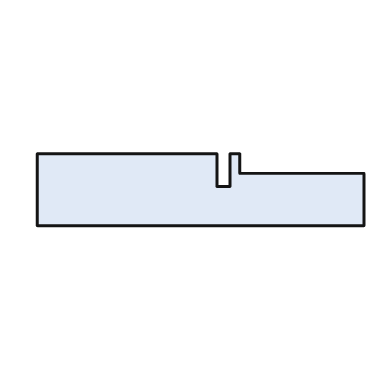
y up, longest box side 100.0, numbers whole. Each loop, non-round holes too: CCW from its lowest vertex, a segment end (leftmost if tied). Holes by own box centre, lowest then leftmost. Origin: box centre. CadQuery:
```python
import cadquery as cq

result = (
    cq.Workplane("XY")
    .moveTo(-50.0, -11.0)
    .lineTo(50.0, -11.0)
    .lineTo(50.0, 5.0)
    .lineTo(12.0, 5.0)
    .lineTo(12.0, 11.0)
    .lineTo(9.0, 11.0)
    .lineTo(9.0, 1.0)
    .lineTo(5.0, 1.0)
    .lineTo(5.0, 11.0)
    .lineTo(-50.0, 11.0)
    .close()
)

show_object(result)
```